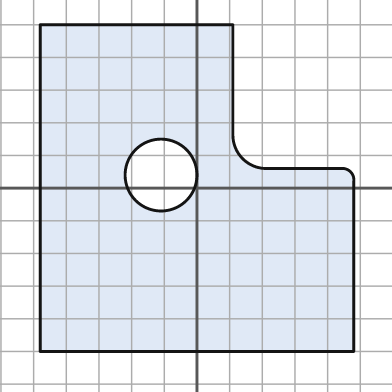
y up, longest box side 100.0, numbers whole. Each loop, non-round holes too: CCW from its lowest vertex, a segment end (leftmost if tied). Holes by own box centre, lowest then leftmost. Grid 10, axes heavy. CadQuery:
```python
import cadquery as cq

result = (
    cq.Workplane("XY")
    .moveTo(-48.0, -50.0)
    .lineTo(48.0, -50.0)
    .lineTo(48.0, 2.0)
    .threePointArc((47.0, 5.0), (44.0, 6.0))
    .lineTo(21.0, 6.0)
    .threePointArc((14.0, 9.0), (11.0, 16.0))
    .lineTo(11.0, 50.0)
    .lineTo(-48.0, 50.0)
    .close()
    .moveTo(-11.0, 4.0)
    .circle(11.0)
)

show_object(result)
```